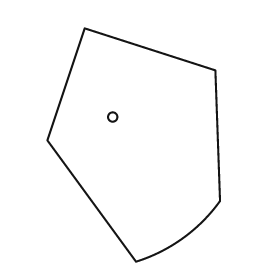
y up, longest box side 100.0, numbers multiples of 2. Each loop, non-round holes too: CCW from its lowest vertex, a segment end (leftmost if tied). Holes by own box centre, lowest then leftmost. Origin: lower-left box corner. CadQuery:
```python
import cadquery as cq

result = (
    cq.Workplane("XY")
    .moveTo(38.0, 0.0)
    .threePointArc((58.0, 10.0), (74.0, 26.0))
    .lineTo(72.0, 82.0)
    .lineTo(16.0, 100.0)
    .lineTo(0.0, 52.0)
    .close()
    .moveTo(28.0, 62.0)
    .circle(2.0)
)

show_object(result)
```